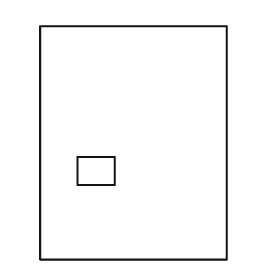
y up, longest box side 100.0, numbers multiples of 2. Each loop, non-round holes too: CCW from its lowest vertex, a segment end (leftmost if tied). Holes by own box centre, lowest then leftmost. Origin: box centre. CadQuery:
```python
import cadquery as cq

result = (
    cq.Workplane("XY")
    .moveTo(-40.0, -50.0)
    .lineTo(40.0, -50.0)
    .lineTo(40.0, 50.0)
    .lineTo(-40.0, 50.0)
    .close()
    .moveTo(-24.0, -18.0)
    .lineTo(-8.0, -18.0)
    .lineTo(-8.0, -6.0)
    .lineTo(-24.0, -6.0)
    .close()
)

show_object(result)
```